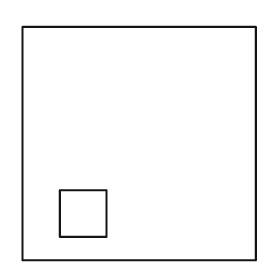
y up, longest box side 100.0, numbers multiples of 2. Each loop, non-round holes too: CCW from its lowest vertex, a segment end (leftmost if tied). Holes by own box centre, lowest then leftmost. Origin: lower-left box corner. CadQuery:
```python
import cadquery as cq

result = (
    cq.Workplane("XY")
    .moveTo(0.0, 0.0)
    .lineTo(100.0, 0.0)
    .lineTo(100.0, 100.0)
    .lineTo(0.0, 100.0)
    .close()
    .moveTo(16.0, 10.0)
    .lineTo(36.0, 10.0)
    .lineTo(36.0, 30.0)
    .lineTo(16.0, 30.0)
    .close()
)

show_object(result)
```